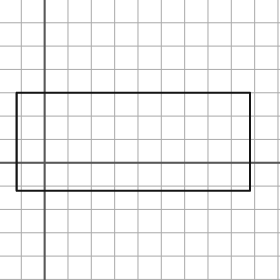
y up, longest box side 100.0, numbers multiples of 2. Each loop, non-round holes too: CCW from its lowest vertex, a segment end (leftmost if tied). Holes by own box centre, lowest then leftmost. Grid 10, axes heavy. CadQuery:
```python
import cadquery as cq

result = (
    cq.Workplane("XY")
    .moveTo(-12.0, -12.0)
    .lineTo(88.0, -12.0)
    .lineTo(88.0, 30.0)
    .lineTo(-12.0, 30.0)
    .close()
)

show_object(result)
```